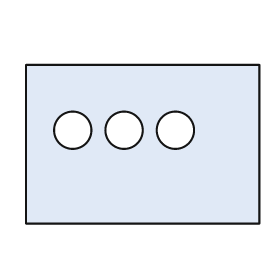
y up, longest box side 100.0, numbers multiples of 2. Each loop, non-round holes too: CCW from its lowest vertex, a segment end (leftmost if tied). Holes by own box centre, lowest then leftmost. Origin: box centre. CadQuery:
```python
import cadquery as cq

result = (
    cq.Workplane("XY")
    .moveTo(-50.0, -34.0)
    .lineTo(50.0, -34.0)
    .lineTo(50.0, 34.0)
    .lineTo(-50.0, 34.0)
    .close()
    .moveTo(-30.0, 6.0)
    .circle(8.0)
    .moveTo(-8.0, 6.0)
    .circle(8.0)
    .moveTo(14.0, 6.0)
    .circle(8.0)
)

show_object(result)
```